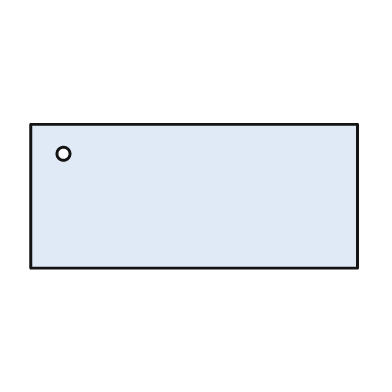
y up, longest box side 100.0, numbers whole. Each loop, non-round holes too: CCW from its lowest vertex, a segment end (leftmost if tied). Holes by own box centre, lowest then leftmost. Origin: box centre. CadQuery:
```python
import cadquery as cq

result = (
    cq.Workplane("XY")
    .moveTo(-50.0, -22.0)
    .lineTo(50.0, -22.0)
    .lineTo(50.0, 22.0)
    .lineTo(-50.0, 22.0)
    .close()
    .moveTo(-40.0, 13.0)
    .circle(2.0)
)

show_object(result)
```